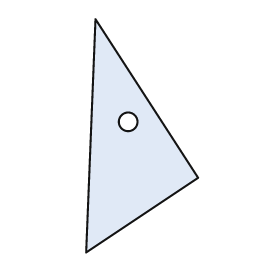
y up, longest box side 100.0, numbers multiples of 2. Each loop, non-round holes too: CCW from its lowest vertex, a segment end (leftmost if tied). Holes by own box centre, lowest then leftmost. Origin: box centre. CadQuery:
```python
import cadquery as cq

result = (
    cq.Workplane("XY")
    .moveTo(-24.0, -50.0)
    .lineTo(24.0, -18.0)
    .lineTo(-20.0, 50.0)
    .close()
    .moveTo(-6.0, 6.0)
    .circle(4.0)
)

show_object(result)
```